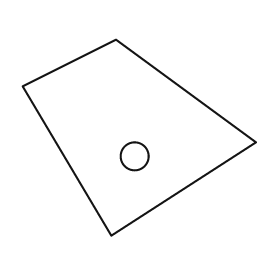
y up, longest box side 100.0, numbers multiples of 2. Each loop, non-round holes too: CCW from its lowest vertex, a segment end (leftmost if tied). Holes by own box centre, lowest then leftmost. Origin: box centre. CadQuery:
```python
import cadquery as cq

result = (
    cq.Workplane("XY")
    .moveTo(-12.0, -42.0)
    .lineTo(50.0, -2.0)
    .lineTo(-10.0, 42.0)
    .lineTo(-50.0, 22.0)
    .close()
    .moveTo(-2.0, -8.0)
    .circle(6.0)
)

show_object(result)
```